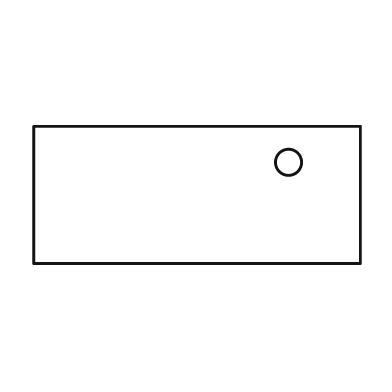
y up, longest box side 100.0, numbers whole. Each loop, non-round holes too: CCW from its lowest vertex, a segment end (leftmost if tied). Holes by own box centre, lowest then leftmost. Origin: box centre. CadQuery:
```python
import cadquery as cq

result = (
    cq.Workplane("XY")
    .moveTo(-50.0, -21.0)
    .lineTo(50.0, -21.0)
    .lineTo(50.0, 21.0)
    .lineTo(-50.0, 21.0)
    .close()
    .moveTo(28.0, 10.0)
    .circle(4.0)
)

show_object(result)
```